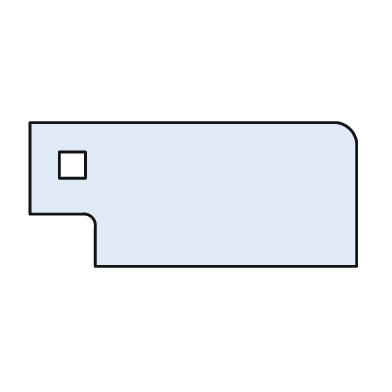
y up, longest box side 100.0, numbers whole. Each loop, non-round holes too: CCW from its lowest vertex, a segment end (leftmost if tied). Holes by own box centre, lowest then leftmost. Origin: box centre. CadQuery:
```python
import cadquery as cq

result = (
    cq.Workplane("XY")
    .moveTo(-30.0, -22.0)
    .lineTo(50.0, -22.0)
    .lineTo(50.0, 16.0)
    .threePointArc((48.0, 20.0), (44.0, 22.0))
    .lineTo(-50.0, 22.0)
    .lineTo(-50.0, -6.0)
    .lineTo(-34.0, -6.0)
    .threePointArc((-31.0, -7.0), (-30.0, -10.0))
    .close()
    .moveTo(-41.0, 5.0)
    .lineTo(-33.0, 5.0)
    .lineTo(-33.0, 13.0)
    .lineTo(-41.0, 13.0)
    .close()
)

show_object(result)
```